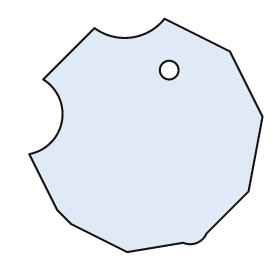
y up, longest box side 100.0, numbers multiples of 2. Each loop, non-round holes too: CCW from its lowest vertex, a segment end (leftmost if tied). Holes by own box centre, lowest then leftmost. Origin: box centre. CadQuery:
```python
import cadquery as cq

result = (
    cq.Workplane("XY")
    .moveTo(-8.0, -50.0)
    .lineTo(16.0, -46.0)
    .threePointArc((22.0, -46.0), (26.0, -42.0))
    .lineTo(44.0, -24.0)
    .lineTo(50.0, 8.0)
    .lineTo(36.0, 36.0)
    .lineTo(8.0, 50.0)
    .threePointArc((-6.0, 42.0), (-22.0, 46.0))
    .lineTo(-44.0, 24.0)
    .threePointArc((-36.0, 6.0), (-50.0, -8.0))
    .lineTo(-38.0, -32.0)
    .lineTo(-32.0, -38.0)
    .close()
    .moveTo(10.0, 28.0)
    .circle(4.0)
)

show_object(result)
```